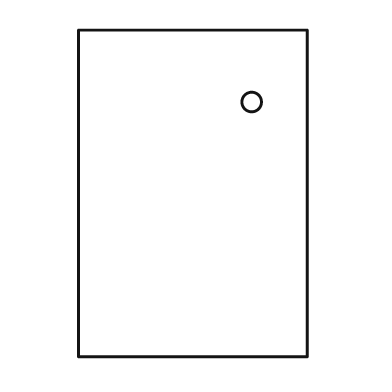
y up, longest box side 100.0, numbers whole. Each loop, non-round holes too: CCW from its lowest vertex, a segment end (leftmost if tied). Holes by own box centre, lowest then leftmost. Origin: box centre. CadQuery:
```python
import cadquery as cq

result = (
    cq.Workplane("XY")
    .moveTo(-35.0, -50.0)
    .lineTo(35.0, -50.0)
    .lineTo(35.0, 50.0)
    .lineTo(-35.0, 50.0)
    .close()
    .moveTo(18.0, 28.0)
    .circle(3.0)
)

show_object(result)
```